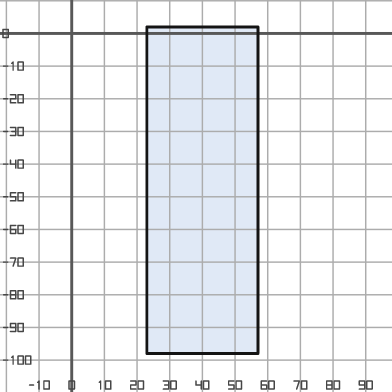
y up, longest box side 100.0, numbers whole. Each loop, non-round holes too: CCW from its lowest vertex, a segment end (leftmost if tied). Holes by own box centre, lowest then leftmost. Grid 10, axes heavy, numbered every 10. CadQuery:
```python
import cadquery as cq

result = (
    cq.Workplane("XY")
    .moveTo(23.0, -98.0)
    .lineTo(57.0, -98.0)
    .lineTo(57.0, 2.0)
    .lineTo(23.0, 2.0)
    .close()
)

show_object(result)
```